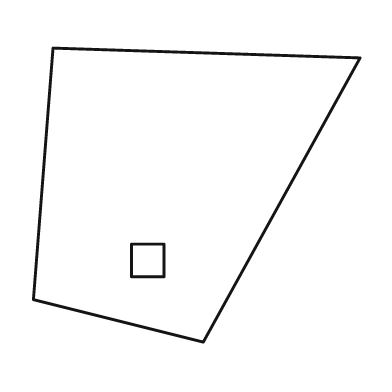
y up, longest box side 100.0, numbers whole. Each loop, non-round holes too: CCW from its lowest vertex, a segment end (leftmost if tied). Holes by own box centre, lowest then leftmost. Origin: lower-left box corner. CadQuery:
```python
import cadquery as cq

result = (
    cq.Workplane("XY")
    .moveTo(52.0, 0.0)
    .lineTo(100.0, 87.0)
    .lineTo(6.0, 90.0)
    .lineTo(0.0, 13.0)
    .close()
    .moveTo(30.0, 20.0)
    .lineTo(40.0, 20.0)
    .lineTo(40.0, 30.0)
    .lineTo(30.0, 30.0)
    .close()
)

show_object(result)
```